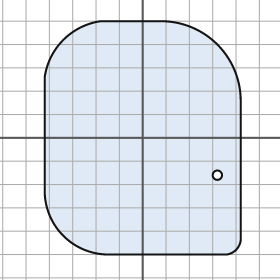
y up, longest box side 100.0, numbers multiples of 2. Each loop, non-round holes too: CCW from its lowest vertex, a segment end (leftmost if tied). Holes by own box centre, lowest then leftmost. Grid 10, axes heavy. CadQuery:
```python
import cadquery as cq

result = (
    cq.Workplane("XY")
    .moveTo(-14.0, -50.0)
    .lineTo(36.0, -50.0)
    .threePointArc((40.0, -48.0), (42.0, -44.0))
    .lineTo(42.0, 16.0)
    .threePointArc((32.0, 40.0), (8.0, 50.0))
    .lineTo(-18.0, 50.0)
    .threePointArc((-34.0, 42.0), (-42.0, 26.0))
    .lineTo(-42.0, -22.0)
    .threePointArc((-34.0, -42.0), (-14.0, -50.0))
    .close()
    .moveTo(32.0, -16.0)
    .circle(2.0)
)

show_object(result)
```